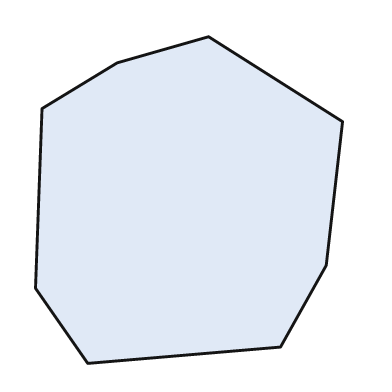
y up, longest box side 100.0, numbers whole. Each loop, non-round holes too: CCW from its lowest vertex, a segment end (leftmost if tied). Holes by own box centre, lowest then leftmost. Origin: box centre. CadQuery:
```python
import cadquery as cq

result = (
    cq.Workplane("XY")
    .moveTo(-31.0, -50.0)
    .lineTo(28.0, -45.0)
    .lineTo(42.0, -20.0)
    .lineTo(47.0, 24.0)
    .lineTo(6.0, 50.0)
    .lineTo(-22.0, 42.0)
    .lineTo(-45.0, 28.0)
    .lineTo(-47.0, -27.0)
    .close()
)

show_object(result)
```